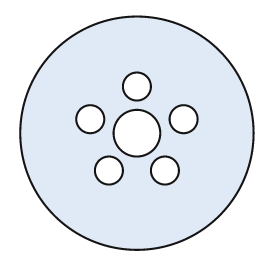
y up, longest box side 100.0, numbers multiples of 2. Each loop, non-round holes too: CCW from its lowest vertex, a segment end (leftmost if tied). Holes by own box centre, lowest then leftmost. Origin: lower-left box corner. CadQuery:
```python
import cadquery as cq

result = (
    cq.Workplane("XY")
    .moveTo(50.0, 50.0)
    .circle(50.0)
    .moveTo(38.0, 34.0)
    .circle(6.0)
    .moveTo(62.0, 34.0)
    .circle(6.0)
    .moveTo(50.0, 50.0)
    .circle(10.0)
    .moveTo(30.0, 56.0)
    .circle(6.0)
    .moveTo(70.0, 56.0)
    .circle(6.0)
    .moveTo(50.0, 70.0)
    .circle(6.0)
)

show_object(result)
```